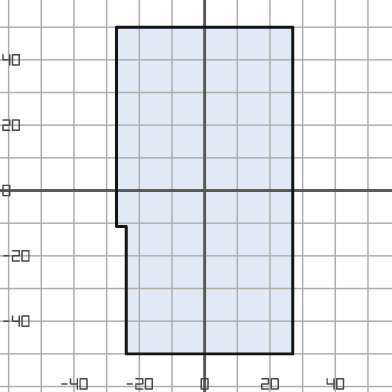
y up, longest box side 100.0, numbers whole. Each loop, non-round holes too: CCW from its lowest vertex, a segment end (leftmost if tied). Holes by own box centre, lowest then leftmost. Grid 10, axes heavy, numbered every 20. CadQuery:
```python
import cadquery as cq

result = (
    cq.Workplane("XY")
    .moveTo(-24.0, -50.0)
    .lineTo(27.0, -50.0)
    .lineTo(27.0, 50.0)
    .lineTo(-27.0, 50.0)
    .lineTo(-27.0, -11.0)
    .lineTo(-24.0, -11.0)
    .close()
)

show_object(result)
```